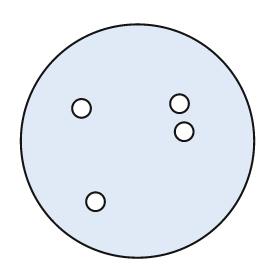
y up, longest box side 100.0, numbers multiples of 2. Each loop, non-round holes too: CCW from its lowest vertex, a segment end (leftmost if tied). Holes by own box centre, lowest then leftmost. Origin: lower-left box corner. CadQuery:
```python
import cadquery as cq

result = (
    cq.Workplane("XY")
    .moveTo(50.0, 50.0)
    .circle(50.0)
    .moveTo(32.0, 24.0)
    .circle(4.0)
    .moveTo(70.0, 54.0)
    .circle(4.0)
    .moveTo(26.0, 64.0)
    .circle(4.0)
    .moveTo(68.0, 66.0)
    .circle(4.0)
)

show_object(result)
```